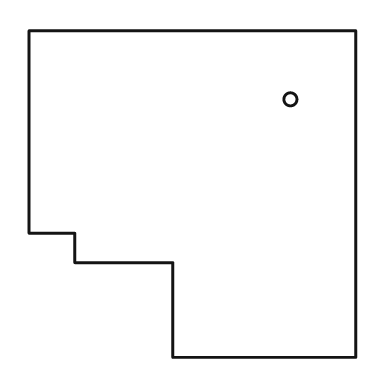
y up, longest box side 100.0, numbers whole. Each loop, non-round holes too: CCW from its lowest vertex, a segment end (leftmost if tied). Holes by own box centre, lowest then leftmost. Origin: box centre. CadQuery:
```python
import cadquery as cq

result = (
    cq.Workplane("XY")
    .moveTo(-6.0, -50.0)
    .lineTo(50.0, -50.0)
    .lineTo(50.0, 50.0)
    .lineTo(-50.0, 50.0)
    .lineTo(-50.0, -12.0)
    .lineTo(-36.0, -12.0)
    .lineTo(-36.0, -21.0)
    .lineTo(-6.0, -21.0)
    .close()
    .moveTo(30.0, 29.0)
    .circle(2.0)
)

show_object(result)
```